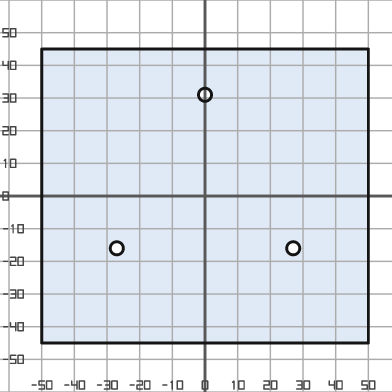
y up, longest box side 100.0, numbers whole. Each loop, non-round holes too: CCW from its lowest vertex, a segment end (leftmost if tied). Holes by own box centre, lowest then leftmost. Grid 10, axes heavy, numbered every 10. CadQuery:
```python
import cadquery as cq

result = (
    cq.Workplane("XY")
    .moveTo(-50.0, -45.0)
    .lineTo(50.0, -45.0)
    .lineTo(50.0, 45.0)
    .lineTo(-50.0, 45.0)
    .close()
    .moveTo(-27.0, -16.0)
    .circle(2.0)
    .moveTo(27.0, -16.0)
    .circle(2.0)
    .moveTo(0.0, 31.0)
    .circle(2.0)
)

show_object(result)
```